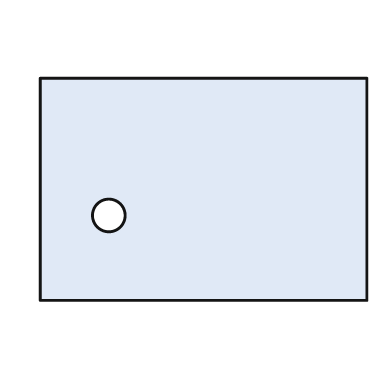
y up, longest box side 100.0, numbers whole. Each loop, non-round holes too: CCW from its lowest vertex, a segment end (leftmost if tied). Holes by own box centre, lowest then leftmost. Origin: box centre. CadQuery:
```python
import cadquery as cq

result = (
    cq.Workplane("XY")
    .moveTo(-50.0, -34.0)
    .lineTo(50.0, -34.0)
    .lineTo(50.0, 34.0)
    .lineTo(-50.0, 34.0)
    .close()
    .moveTo(-29.0, -8.0)
    .circle(5.0)
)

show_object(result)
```